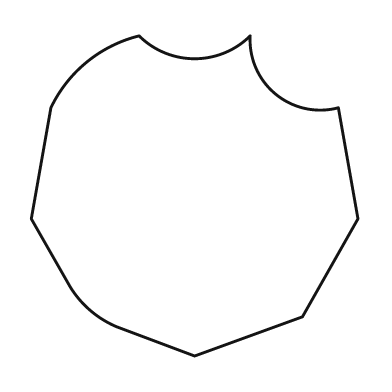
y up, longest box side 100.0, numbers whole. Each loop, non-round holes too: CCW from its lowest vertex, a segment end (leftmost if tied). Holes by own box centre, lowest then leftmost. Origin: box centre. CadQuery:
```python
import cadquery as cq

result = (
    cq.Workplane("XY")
    .moveTo(0.0, -49.0)
    .lineTo(33.0, -37.0)
    .lineTo(50.0, -7.0)
    .lineTo(44.0, 27.0)
    .threePointArc((25.0, 31.0), (17.0, 49.0))
    .threePointArc((0.0, 42.0), (-17.0, 49.0))
    .threePointArc((-33.0, 41.0), (-44.0, 27.0))
    .lineTo(-50.0, -7.0)
    .lineTo(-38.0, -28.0)
    .threePointArc((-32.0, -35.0), (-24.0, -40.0))
    .close()
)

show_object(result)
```